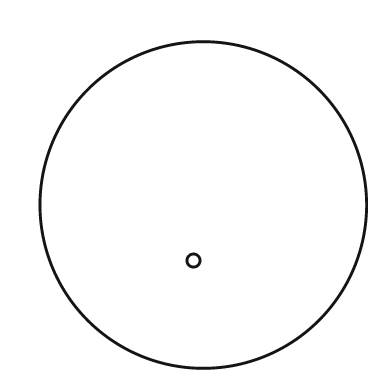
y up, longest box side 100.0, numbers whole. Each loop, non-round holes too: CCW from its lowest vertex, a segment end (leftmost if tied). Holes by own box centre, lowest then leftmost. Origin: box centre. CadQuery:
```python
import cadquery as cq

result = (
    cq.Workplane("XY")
    .moveTo(0.0, 0.0)
    .circle(50.0)
    .moveTo(-3.0, -17.0)
    .circle(2.0)
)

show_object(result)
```